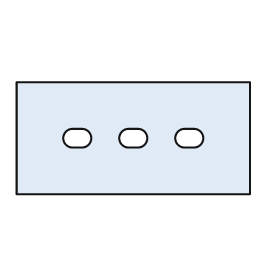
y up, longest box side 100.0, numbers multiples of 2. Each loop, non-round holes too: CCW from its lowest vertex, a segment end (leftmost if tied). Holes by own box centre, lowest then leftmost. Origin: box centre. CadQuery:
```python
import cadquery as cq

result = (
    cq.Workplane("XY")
    .moveTo(-50.0, -24.0)
    .lineTo(50.0, -24.0)
    .lineTo(50.0, 24.0)
    .lineTo(-50.0, 24.0)
    .close()
    .moveTo(-26.0, -4.0)
    .lineTo(-22.0, -4.0)
    .threePointArc((-18.0, 0.0), (-22.0, 4.0))
    .lineTo(-26.0, 4.0)
    .threePointArc((-30.0, 0.0), (-26.0, -4.0))
    .close()
    .moveTo(-2.0, -4.0)
    .lineTo(2.0, -4.0)
    .threePointArc((6.0, 0.0), (2.0, 4.0))
    .lineTo(-2.0, 4.0)
    .threePointArc((-6.0, 0.0), (-2.0, -4.0))
    .close()
    .moveTo(22.0, -4.0)
    .lineTo(26.0, -4.0)
    .threePointArc((30.0, 0.0), (26.0, 4.0))
    .lineTo(22.0, 4.0)
    .threePointArc((18.0, 0.0), (22.0, -4.0))
    .close()
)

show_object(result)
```